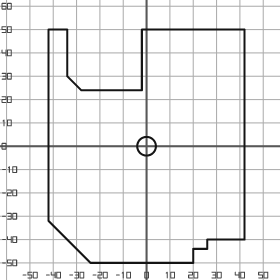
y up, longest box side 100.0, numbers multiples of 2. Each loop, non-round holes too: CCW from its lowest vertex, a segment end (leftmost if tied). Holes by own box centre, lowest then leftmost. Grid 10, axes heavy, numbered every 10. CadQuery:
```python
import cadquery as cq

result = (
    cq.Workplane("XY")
    .moveTo(-24.0, -50.0)
    .lineTo(20.0, -50.0)
    .lineTo(20.0, -44.0)
    .lineTo(26.0, -44.0)
    .lineTo(26.0, -40.0)
    .lineTo(42.0, -40.0)
    .lineTo(42.0, 50.0)
    .lineTo(-2.0, 50.0)
    .lineTo(-2.0, 24.0)
    .lineTo(-28.0, 24.0)
    .lineTo(-34.0, 30.0)
    .lineTo(-34.0, 50.0)
    .lineTo(-42.0, 50.0)
    .lineTo(-42.0, -32.0)
    .close()
    .moveTo(0.0, 0.0)
    .circle(4.0)
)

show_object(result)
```